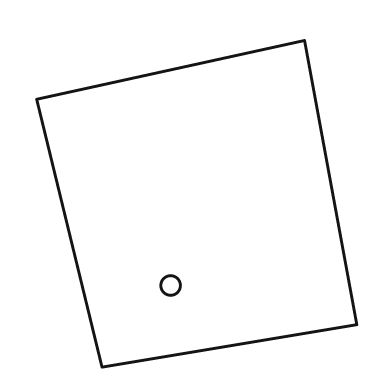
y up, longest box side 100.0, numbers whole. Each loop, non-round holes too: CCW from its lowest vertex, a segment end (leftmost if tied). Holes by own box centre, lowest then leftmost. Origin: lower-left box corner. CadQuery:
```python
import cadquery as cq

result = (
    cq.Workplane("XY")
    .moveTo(20.0, 0.0)
    .lineTo(98.0, 13.0)
    .lineTo(82.0, 100.0)
    .lineTo(0.0, 82.0)
    .close()
    .moveTo(41.0, 25.0)
    .circle(3.0)
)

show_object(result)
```